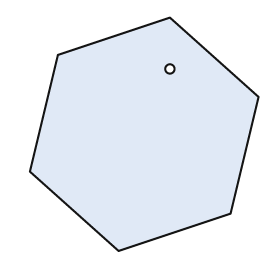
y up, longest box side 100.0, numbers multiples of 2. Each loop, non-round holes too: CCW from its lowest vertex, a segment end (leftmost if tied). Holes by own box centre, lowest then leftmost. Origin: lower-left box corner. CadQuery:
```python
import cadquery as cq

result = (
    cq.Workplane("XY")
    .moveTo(38.0, 0.0)
    .lineTo(86.0, 16.0)
    .lineTo(98.0, 66.0)
    .lineTo(60.0, 100.0)
    .lineTo(12.0, 84.0)
    .lineTo(0.0, 34.0)
    .close()
    .moveTo(60.0, 78.0)
    .circle(2.0)
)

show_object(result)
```